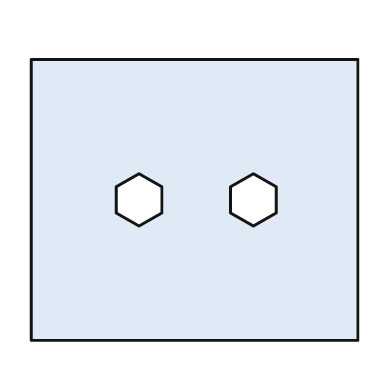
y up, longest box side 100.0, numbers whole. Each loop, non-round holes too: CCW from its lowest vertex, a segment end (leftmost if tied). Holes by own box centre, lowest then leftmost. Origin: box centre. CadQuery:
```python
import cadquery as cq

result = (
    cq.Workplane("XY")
    .moveTo(-50.0, -43.0)
    .lineTo(50.0, -43.0)
    .lineTo(50.0, 43.0)
    .lineTo(-50.0, 43.0)
    .close()
    .moveTo(-17.0, -8.0)
    .lineTo(-10.0, -4.0)
    .lineTo(-10.0, 4.0)
    .lineTo(-17.0, 8.0)
    .lineTo(-24.0, 4.0)
    .lineTo(-24.0, -4.0)
    .close()
    .moveTo(18.0, -8.0)
    .lineTo(25.0, -4.0)
    .lineTo(25.0, 4.0)
    .lineTo(18.0, 8.0)
    .lineTo(11.0, 4.0)
    .lineTo(11.0, -4.0)
    .close()
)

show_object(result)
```